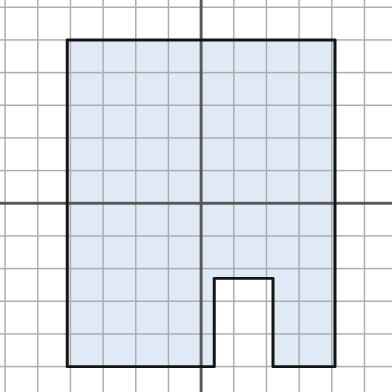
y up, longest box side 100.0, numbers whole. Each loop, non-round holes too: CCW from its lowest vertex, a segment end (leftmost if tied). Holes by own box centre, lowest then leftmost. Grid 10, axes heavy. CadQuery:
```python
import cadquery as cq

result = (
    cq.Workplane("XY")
    .moveTo(-41.0, -50.0)
    .lineTo(4.0, -50.0)
    .lineTo(4.0, -23.0)
    .lineTo(22.0, -23.0)
    .lineTo(22.0, -50.0)
    .lineTo(41.0, -50.0)
    .lineTo(41.0, 50.0)
    .lineTo(-41.0, 50.0)
    .close()
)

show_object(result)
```